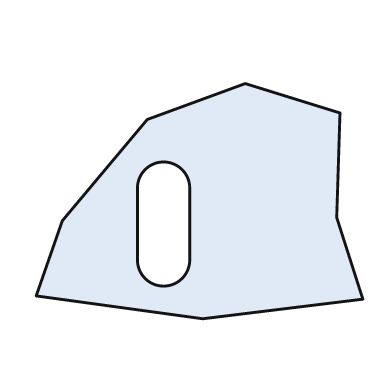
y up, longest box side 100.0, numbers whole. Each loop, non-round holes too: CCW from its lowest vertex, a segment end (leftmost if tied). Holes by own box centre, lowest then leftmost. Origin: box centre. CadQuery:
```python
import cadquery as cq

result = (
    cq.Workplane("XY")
    .moveTo(1.0, -36.0)
    .lineTo(50.0, -30.0)
    .lineTo(42.0, -5.0)
    .lineTo(43.0, 27.0)
    .lineTo(14.0, 36.0)
    .lineTo(-16.0, 25.0)
    .lineTo(-42.0, -6.0)
    .lineTo(-50.0, -29.0)
    .close()
    .moveTo(-19.0, -18.0)
    .threePointArc((-11.0, -26.0), (-3.0, -18.0))
    .lineTo(-3.0, 4.0)
    .threePointArc((-11.0, 12.0), (-19.0, 4.0))
    .close()
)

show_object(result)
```